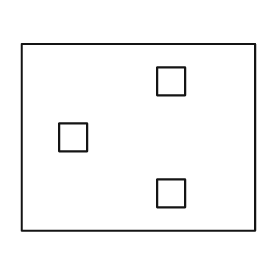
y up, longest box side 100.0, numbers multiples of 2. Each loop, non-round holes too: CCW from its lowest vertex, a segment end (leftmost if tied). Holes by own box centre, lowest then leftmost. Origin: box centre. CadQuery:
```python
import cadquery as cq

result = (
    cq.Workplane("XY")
    .moveTo(-50.0, -40.0)
    .lineTo(50.0, -40.0)
    .lineTo(50.0, 40.0)
    .lineTo(-50.0, 40.0)
    .close()
    .moveTo(8.0, -30.0)
    .lineTo(20.0, -30.0)
    .lineTo(20.0, -18.0)
    .lineTo(8.0, -18.0)
    .close()
    .moveTo(-34.0, -6.0)
    .lineTo(-22.0, -6.0)
    .lineTo(-22.0, 6.0)
    .lineTo(-34.0, 6.0)
    .close()
    .moveTo(8.0, 18.0)
    .lineTo(20.0, 18.0)
    .lineTo(20.0, 30.0)
    .lineTo(8.0, 30.0)
    .close()
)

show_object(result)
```